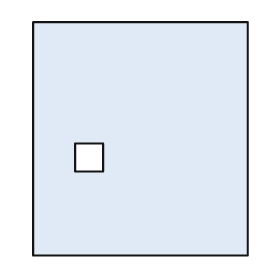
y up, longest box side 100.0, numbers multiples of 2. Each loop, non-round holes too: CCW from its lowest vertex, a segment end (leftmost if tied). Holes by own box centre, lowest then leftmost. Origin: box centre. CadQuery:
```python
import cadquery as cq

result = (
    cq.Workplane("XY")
    .moveTo(-46.0, -50.0)
    .lineTo(46.0, -50.0)
    .lineTo(46.0, 50.0)
    .lineTo(-46.0, 50.0)
    .close()
    .moveTo(-28.0, -14.0)
    .lineTo(-16.0, -14.0)
    .lineTo(-16.0, -2.0)
    .lineTo(-28.0, -2.0)
    .close()
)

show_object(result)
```